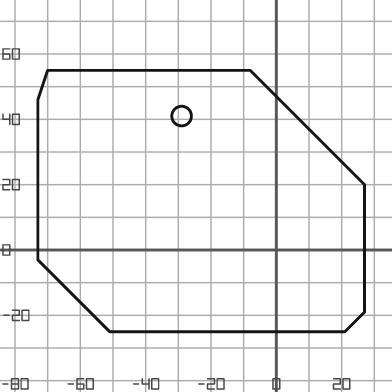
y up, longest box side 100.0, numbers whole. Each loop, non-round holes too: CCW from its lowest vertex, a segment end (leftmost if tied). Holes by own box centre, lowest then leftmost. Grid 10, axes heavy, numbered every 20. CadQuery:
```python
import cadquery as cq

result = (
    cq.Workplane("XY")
    .moveTo(-51.0, -25.0)
    .lineTo(21.0, -25.0)
    .lineTo(27.0, -19.0)
    .lineTo(27.0, 20.0)
    .lineTo(-8.0, 55.0)
    .lineTo(-70.0, 55.0)
    .lineTo(-73.0, 46.0)
    .lineTo(-73.0, -3.0)
    .close()
    .moveTo(-29.0, 41.0)
    .circle(3.0)
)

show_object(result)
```